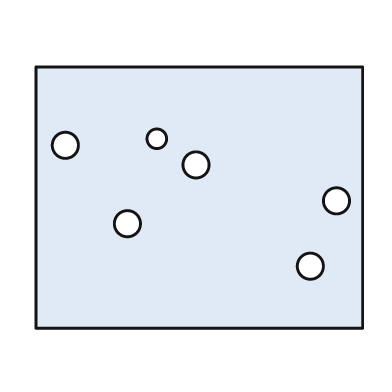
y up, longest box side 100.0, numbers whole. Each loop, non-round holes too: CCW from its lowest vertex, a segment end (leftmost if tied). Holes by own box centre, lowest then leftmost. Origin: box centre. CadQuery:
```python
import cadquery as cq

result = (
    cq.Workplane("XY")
    .moveTo(-50.0, -40.0)
    .lineTo(50.0, -40.0)
    .lineTo(50.0, 40.0)
    .lineTo(-50.0, 40.0)
    .close()
    .moveTo(34.0, -21.0)
    .circle(4.0)
    .moveTo(-22.0, -8.0)
    .circle(4.0)
    .moveTo(42.0, -1.0)
    .circle(4.0)
    .moveTo(-1.0, 10.0)
    .circle(4.0)
    .moveTo(-41.0, 16.0)
    .circle(4.0)
    .moveTo(-13.0, 18.0)
    .circle(3.0)
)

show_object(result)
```